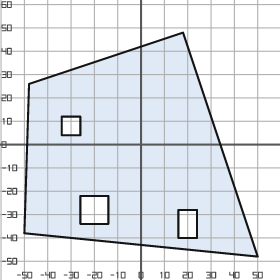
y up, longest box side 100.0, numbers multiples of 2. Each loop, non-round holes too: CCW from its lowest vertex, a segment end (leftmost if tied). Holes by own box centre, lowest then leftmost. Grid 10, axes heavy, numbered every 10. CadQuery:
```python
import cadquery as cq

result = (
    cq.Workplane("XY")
    .moveTo(50.0, -48.0)
    .lineTo(18.0, 48.0)
    .lineTo(-48.0, 26.0)
    .lineTo(-50.0, -38.0)
    .close()
    .moveTo(16.0, -40.0)
    .lineTo(24.0, -40.0)
    .lineTo(24.0, -28.0)
    .lineTo(16.0, -28.0)
    .close()
    .moveTo(-26.0, -34.0)
    .lineTo(-14.0, -34.0)
    .lineTo(-14.0, -22.0)
    .lineTo(-26.0, -22.0)
    .close()
    .moveTo(-34.0, 4.0)
    .lineTo(-26.0, 4.0)
    .lineTo(-26.0, 12.0)
    .lineTo(-34.0, 12.0)
    .close()
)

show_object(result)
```